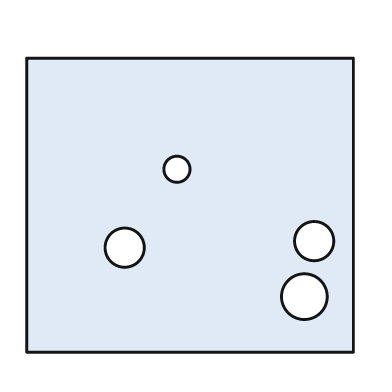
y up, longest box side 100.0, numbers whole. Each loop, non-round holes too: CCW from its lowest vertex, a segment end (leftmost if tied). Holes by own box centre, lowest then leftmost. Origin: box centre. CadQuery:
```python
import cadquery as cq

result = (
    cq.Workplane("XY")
    .moveTo(-50.0, -45.0)
    .lineTo(50.0, -45.0)
    .lineTo(50.0, 45.0)
    .lineTo(-50.0, 45.0)
    .close()
    .moveTo(35.0, -28.0)
    .circle(7.0)
    .moveTo(-20.0, -13.0)
    .circle(6.0)
    .moveTo(38.0, -11.0)
    .circle(6.0)
    .moveTo(-4.0, 11.0)
    .circle(4.0)
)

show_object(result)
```